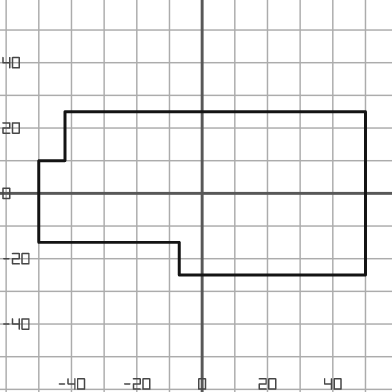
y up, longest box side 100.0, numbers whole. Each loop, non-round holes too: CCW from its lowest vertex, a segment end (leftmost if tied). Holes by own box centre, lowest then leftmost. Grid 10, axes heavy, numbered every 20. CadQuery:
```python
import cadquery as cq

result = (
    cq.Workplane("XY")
    .moveTo(-7.0, -25.0)
    .lineTo(50.0, -25.0)
    .lineTo(50.0, 25.0)
    .lineTo(-42.0, 25.0)
    .lineTo(-42.0, 10.0)
    .lineTo(-50.0, 10.0)
    .lineTo(-50.0, -15.0)
    .lineTo(-7.0, -15.0)
    .close()
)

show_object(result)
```